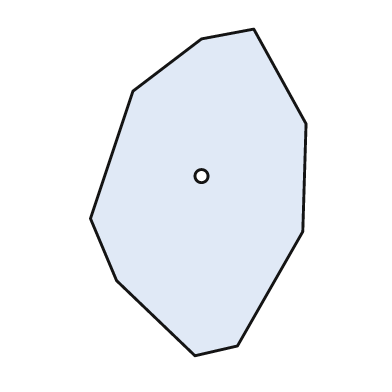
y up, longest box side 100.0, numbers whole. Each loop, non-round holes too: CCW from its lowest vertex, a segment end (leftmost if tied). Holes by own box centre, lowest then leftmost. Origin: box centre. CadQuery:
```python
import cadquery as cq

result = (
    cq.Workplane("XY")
    .moveTo(-1.0, -50.0)
    .lineTo(12.0, -47.0)
    .lineTo(32.0, -12.0)
    .lineTo(33.0, 21.0)
    .lineTo(17.0, 50.0)
    .lineTo(1.0, 47.0)
    .lineTo(-20.0, 31.0)
    .lineTo(-33.0, -8.0)
    .lineTo(-25.0, -27.0)
    .close()
    .moveTo(1.0, 5.0)
    .circle(2.0)
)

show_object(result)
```